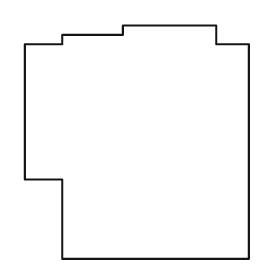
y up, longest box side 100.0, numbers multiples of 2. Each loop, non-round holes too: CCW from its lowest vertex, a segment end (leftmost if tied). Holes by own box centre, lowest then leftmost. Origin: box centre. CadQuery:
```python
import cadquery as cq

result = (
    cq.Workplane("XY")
    .moveTo(-32.0, -50.0)
    .lineTo(48.0, -50.0)
    .lineTo(48.0, 42.0)
    .lineTo(34.0, 42.0)
    .lineTo(34.0, 50.0)
    .lineTo(-6.0, 50.0)
    .lineTo(-6.0, 46.0)
    .lineTo(-32.0, 46.0)
    .lineTo(-32.0, 42.0)
    .lineTo(-48.0, 42.0)
    .lineTo(-48.0, -16.0)
    .lineTo(-32.0, -16.0)
    .close()
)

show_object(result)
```